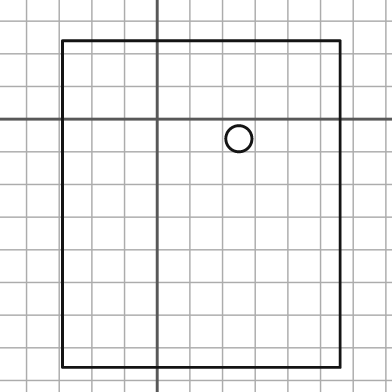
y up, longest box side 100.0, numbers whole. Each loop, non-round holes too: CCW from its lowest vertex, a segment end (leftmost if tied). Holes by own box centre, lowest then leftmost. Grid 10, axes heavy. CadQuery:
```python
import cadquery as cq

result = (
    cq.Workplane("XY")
    .moveTo(-29.0, -76.0)
    .lineTo(56.0, -76.0)
    .lineTo(56.0, 24.0)
    .lineTo(-29.0, 24.0)
    .close()
    .moveTo(25.0, -6.0)
    .circle(4.0)
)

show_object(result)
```